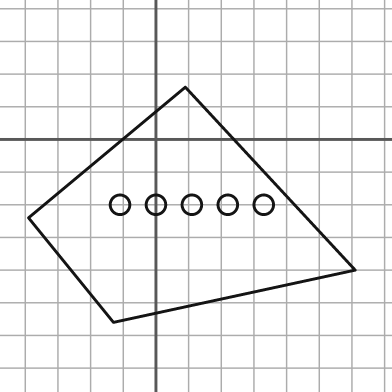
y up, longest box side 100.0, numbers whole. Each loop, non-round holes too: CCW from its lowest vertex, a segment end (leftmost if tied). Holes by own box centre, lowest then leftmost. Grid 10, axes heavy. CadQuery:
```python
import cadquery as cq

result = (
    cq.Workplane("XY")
    .moveTo(-13.0, -56.0)
    .lineTo(61.0, -40.0)
    .lineTo(9.0, 16.0)
    .lineTo(-39.0, -24.0)
    .close()
    .moveTo(-11.0, -20.0)
    .circle(3.0)
    .moveTo(0.0, -20.0)
    .circle(3.0)
    .moveTo(11.0, -20.0)
    .circle(3.0)
    .moveTo(22.0, -20.0)
    .circle(3.0)
    .moveTo(33.0, -20.0)
    .circle(3.0)
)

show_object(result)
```